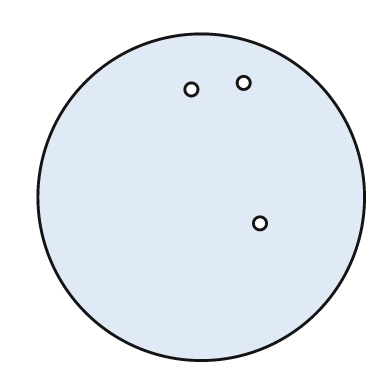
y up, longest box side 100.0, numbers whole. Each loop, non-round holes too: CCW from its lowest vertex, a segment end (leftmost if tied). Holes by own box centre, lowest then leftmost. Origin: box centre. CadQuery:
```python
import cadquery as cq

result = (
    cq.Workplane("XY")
    .moveTo(0.0, 0.0)
    .circle(50.0)
    .moveTo(18.0, -8.0)
    .circle(2.0)
    .moveTo(-3.0, 33.0)
    .circle(2.0)
    .moveTo(13.0, 35.0)
    .circle(2.0)
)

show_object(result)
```